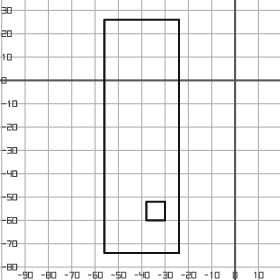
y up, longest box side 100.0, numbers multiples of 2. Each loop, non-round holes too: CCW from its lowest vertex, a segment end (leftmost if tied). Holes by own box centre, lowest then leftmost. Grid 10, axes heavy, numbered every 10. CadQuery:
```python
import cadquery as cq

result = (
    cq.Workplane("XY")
    .moveTo(-56.0, -74.0)
    .lineTo(-24.0, -74.0)
    .lineTo(-24.0, 26.0)
    .lineTo(-56.0, 26.0)
    .close()
    .moveTo(-38.0, -60.0)
    .lineTo(-30.0, -60.0)
    .lineTo(-30.0, -52.0)
    .lineTo(-38.0, -52.0)
    .close()
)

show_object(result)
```